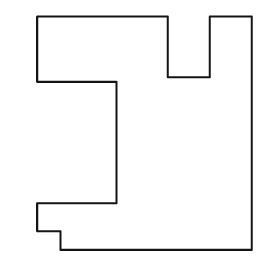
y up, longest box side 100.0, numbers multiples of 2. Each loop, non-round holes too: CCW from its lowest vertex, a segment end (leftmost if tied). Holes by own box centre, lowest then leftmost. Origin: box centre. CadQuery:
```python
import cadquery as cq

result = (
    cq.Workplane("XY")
    .moveTo(-36.0, -50.0)
    .lineTo(46.0, -50.0)
    .lineTo(46.0, 50.0)
    .lineTo(28.0, 50.0)
    .lineTo(28.0, 24.0)
    .lineTo(10.0, 24.0)
    .lineTo(10.0, 50.0)
    .lineTo(-46.0, 50.0)
    .lineTo(-46.0, 22.0)
    .lineTo(-12.0, 22.0)
    .lineTo(-12.0, -30.0)
    .lineTo(-46.0, -30.0)
    .lineTo(-46.0, -42.0)
    .lineTo(-36.0, -42.0)
    .close()
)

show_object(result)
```